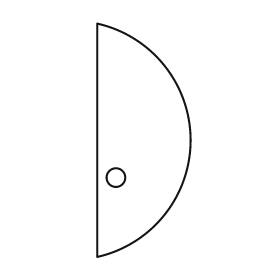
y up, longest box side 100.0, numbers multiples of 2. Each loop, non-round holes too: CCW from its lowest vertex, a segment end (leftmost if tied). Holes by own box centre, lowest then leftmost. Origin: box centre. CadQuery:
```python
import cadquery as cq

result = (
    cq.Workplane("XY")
    .moveTo(-20.0, -50.0)
    .threePointArc((20.0, 0.0), (-20.0, 50.0))
    .close()
    .moveTo(-12.0, -16.0)
    .circle(4.0)
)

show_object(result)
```